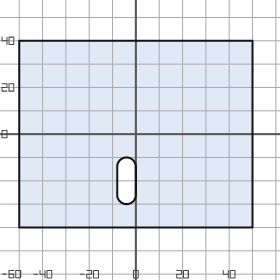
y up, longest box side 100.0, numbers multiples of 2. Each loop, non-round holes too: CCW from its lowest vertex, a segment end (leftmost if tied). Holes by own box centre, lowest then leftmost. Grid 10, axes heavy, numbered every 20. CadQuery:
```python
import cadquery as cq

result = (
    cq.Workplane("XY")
    .moveTo(-50.0, -40.0)
    .lineTo(50.0, -40.0)
    .lineTo(50.0, 40.0)
    .lineTo(-50.0, 40.0)
    .close()
    .moveTo(-8.0, -26.0)
    .threePointArc((-4.0, -30.0), (0.0, -26.0))
    .lineTo(0.0, -14.0)
    .threePointArc((-4.0, -10.0), (-8.0, -14.0))
    .close()
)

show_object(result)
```